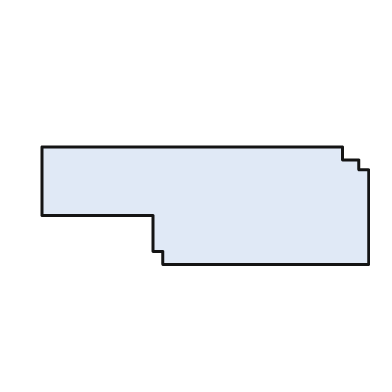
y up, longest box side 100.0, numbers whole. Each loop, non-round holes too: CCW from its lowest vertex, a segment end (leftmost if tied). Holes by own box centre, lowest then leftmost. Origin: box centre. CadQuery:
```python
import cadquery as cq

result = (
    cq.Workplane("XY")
    .moveTo(-13.0, -18.0)
    .lineTo(50.0, -18.0)
    .lineTo(50.0, 11.0)
    .lineTo(47.0, 11.0)
    .lineTo(47.0, 14.0)
    .lineTo(42.0, 14.0)
    .lineTo(42.0, 18.0)
    .lineTo(-50.0, 18.0)
    .lineTo(-50.0, -3.0)
    .lineTo(-16.0, -3.0)
    .lineTo(-16.0, -14.0)
    .lineTo(-13.0, -14.0)
    .close()
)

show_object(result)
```